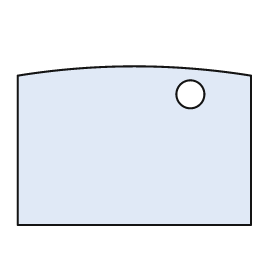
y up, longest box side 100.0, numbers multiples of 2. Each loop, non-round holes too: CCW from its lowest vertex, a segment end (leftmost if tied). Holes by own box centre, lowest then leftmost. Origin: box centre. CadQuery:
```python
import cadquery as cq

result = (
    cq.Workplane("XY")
    .moveTo(-50.0, -34.0)
    .lineTo(50.0, -34.0)
    .lineTo(50.0, 30.0)
    .threePointArc((0.0, 34.0), (-50.0, 30.0))
    .close()
    .moveTo(24.0, 22.0)
    .circle(6.0)
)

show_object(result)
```